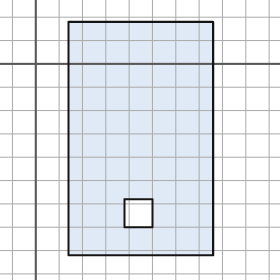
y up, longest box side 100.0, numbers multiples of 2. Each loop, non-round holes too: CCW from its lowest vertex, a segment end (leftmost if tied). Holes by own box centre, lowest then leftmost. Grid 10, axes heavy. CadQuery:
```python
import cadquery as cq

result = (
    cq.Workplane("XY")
    .moveTo(14.0, -82.0)
    .lineTo(76.0, -82.0)
    .lineTo(76.0, 18.0)
    .lineTo(14.0, 18.0)
    .close()
    .moveTo(38.0, -70.0)
    .lineTo(50.0, -70.0)
    .lineTo(50.0, -58.0)
    .lineTo(38.0, -58.0)
    .close()
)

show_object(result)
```